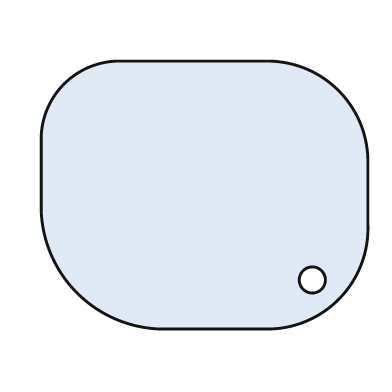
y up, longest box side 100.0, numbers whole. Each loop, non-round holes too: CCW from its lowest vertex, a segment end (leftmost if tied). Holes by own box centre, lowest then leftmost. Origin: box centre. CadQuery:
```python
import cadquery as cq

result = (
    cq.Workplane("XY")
    .moveTo(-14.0, -41.0)
    .lineTo(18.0, -41.0)
    .threePointArc((41.0, -32.0), (50.0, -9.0))
    .lineTo(50.0, 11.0)
    .threePointArc((41.0, 32.0), (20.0, 41.0))
    .lineTo(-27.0, 41.0)
    .threePointArc((-43.0, 34.0), (-50.0, 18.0))
    .lineTo(-50.0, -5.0)
    .threePointArc((-39.0, -30.0), (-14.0, -41.0))
    .close()
    .moveTo(33.0, -26.0)
    .circle(4.0)
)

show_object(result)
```